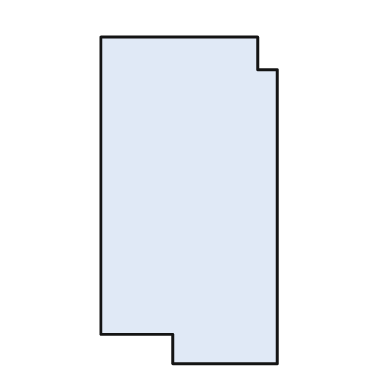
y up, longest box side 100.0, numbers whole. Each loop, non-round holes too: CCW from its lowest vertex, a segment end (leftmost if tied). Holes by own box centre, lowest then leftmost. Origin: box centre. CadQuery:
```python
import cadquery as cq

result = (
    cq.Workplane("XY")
    .moveTo(-5.0, -50.0)
    .lineTo(27.0, -50.0)
    .lineTo(27.0, 40.0)
    .lineTo(21.0, 40.0)
    .lineTo(21.0, 50.0)
    .lineTo(-27.0, 50.0)
    .lineTo(-27.0, -41.0)
    .lineTo(-5.0, -41.0)
    .close()
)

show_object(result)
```